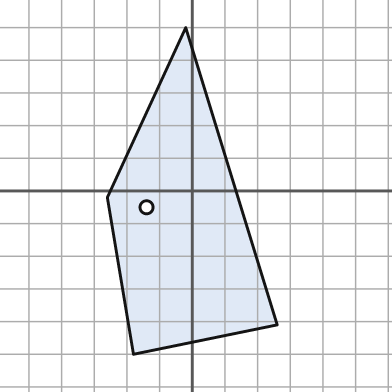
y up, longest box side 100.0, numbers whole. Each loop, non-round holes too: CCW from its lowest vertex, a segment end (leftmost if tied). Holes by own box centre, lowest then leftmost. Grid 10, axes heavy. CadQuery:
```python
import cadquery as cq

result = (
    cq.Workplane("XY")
    .moveTo(-18.0, -50.0)
    .lineTo(26.0, -41.0)
    .lineTo(-2.0, 50.0)
    .lineTo(-26.0, -2.0)
    .close()
    .moveTo(-14.0, -5.0)
    .circle(2.0)
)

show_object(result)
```